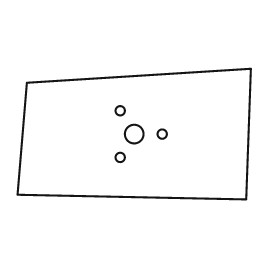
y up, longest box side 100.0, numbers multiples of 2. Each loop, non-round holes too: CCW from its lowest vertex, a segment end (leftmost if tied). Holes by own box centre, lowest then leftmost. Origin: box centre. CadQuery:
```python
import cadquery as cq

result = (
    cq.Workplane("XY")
    .moveTo(48.0, -28.0)
    .lineTo(50.0, 28.0)
    .lineTo(-46.0, 22.0)
    .lineTo(-50.0, -26.0)
    .close()
    .moveTo(-6.0, -10.0)
    .circle(2.0)
    .moveTo(0.0, 0.0)
    .circle(4.0)
    .moveTo(12.0, 0.0)
    .circle(2.0)
    .moveTo(-6.0, 10.0)
    .circle(2.0)
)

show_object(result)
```